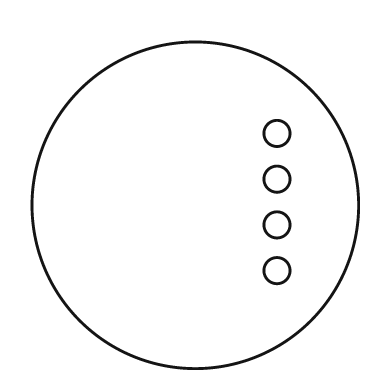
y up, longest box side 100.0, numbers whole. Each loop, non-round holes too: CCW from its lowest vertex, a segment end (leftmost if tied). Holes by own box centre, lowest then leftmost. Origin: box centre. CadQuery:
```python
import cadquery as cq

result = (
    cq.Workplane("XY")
    .moveTo(0.0, 0.0)
    .circle(50.0)
    .moveTo(25.0, -20.0)
    .circle(4.0)
    .moveTo(25.0, -6.0)
    .circle(4.0)
    .moveTo(25.0, 8.0)
    .circle(4.0)
    .moveTo(25.0, 22.0)
    .circle(4.0)
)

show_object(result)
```